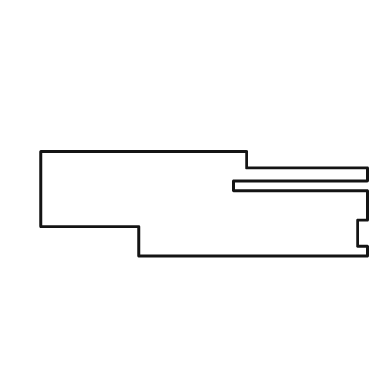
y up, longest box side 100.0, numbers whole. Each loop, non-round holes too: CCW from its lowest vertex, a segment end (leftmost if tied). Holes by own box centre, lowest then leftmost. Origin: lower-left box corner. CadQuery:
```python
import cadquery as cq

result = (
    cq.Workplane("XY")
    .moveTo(30.0, 0.0)
    .lineTo(100.0, 0.0)
    .lineTo(100.0, 3.0)
    .lineTo(97.0, 3.0)
    .lineTo(97.0, 11.0)
    .lineTo(100.0, 11.0)
    .lineTo(100.0, 20.0)
    .lineTo(59.0, 20.0)
    .lineTo(59.0, 23.0)
    .lineTo(100.0, 23.0)
    .lineTo(100.0, 27.0)
    .lineTo(63.0, 27.0)
    .lineTo(63.0, 32.0)
    .lineTo(0.0, 32.0)
    .lineTo(0.0, 9.0)
    .lineTo(30.0, 9.0)
    .close()
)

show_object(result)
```